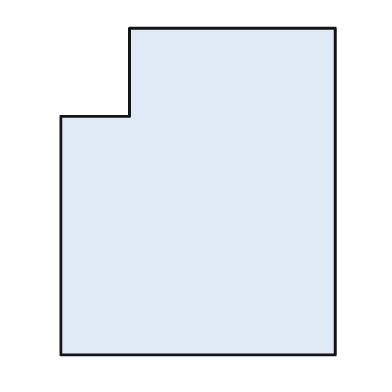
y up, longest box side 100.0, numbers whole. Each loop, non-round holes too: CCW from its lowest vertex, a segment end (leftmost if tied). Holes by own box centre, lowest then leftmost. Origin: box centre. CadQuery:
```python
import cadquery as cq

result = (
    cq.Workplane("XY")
    .moveTo(-42.0, -50.0)
    .lineTo(42.0, -50.0)
    .lineTo(42.0, 50.0)
    .lineTo(-21.0, 50.0)
    .lineTo(-21.0, 23.0)
    .lineTo(-42.0, 23.0)
    .close()
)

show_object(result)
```